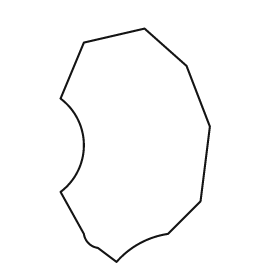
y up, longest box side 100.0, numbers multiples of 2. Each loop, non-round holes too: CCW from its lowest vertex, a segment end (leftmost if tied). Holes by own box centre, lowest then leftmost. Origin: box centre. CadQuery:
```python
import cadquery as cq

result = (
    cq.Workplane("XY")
    .moveTo(-8.0, -50.0)
    .threePointArc((2.0, -42.0), (14.0, -38.0))
    .lineTo(28.0, -24.0)
    .lineTo(32.0, 8.0)
    .lineTo(22.0, 34.0)
    .lineTo(4.0, 50.0)
    .lineTo(-22.0, 44.0)
    .lineTo(-32.0, 20.0)
    .threePointArc((-22.0, 0.0), (-32.0, -20.0))
    .lineTo(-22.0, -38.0)
    .threePointArc((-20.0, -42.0), (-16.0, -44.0))
    .close()
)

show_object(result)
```